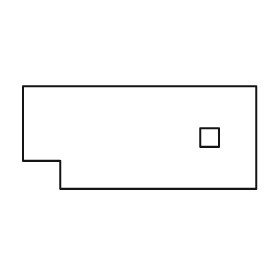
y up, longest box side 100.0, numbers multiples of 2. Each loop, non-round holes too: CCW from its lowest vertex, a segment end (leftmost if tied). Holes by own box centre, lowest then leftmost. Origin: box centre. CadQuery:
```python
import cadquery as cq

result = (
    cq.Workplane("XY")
    .moveTo(-34.0, -22.0)
    .lineTo(50.0, -22.0)
    .lineTo(50.0, 22.0)
    .lineTo(-50.0, 22.0)
    .lineTo(-50.0, -10.0)
    .lineTo(-34.0, -10.0)
    .close()
    .moveTo(26.0, -4.0)
    .lineTo(34.0, -4.0)
    .lineTo(34.0, 4.0)
    .lineTo(26.0, 4.0)
    .close()
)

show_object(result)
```